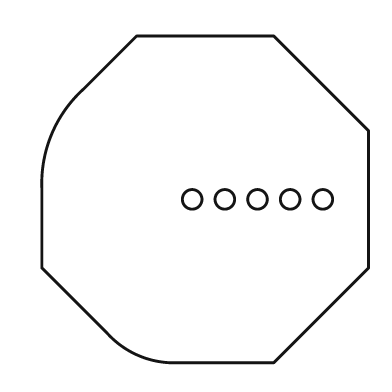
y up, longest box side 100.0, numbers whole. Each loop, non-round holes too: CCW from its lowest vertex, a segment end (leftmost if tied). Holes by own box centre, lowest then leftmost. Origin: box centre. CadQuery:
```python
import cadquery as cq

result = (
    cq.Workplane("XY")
    .moveTo(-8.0, -50.0)
    .lineTo(21.0, -50.0)
    .lineTo(50.0, -21.0)
    .lineTo(50.0, 21.0)
    .lineTo(21.0, 50.0)
    .lineTo(-21.0, 50.0)
    .lineTo(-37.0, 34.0)
    .threePointArc((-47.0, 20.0), (-50.0, 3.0))
    .lineTo(-50.0, -21.0)
    .lineTo(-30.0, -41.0)
    .threePointArc((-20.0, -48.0), (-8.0, -50.0))
    .close()
    .moveTo(-4.0, 0.0)
    .circle(3.0)
    .moveTo(6.0, 0.0)
    .circle(3.0)
    .moveTo(16.0, 0.0)
    .circle(3.0)
    .moveTo(26.0, 0.0)
    .circle(3.0)
    .moveTo(36.0, 0.0)
    .circle(3.0)
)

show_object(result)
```